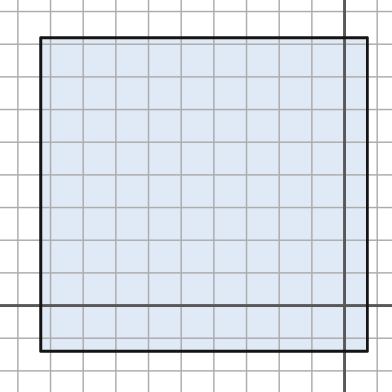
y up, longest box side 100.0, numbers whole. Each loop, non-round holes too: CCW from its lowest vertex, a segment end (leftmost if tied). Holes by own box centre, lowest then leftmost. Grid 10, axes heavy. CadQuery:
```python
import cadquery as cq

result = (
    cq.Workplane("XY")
    .moveTo(-93.0, -14.0)
    .lineTo(7.0, -14.0)
    .lineTo(7.0, 82.0)
    .lineTo(-93.0, 82.0)
    .close()
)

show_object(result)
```